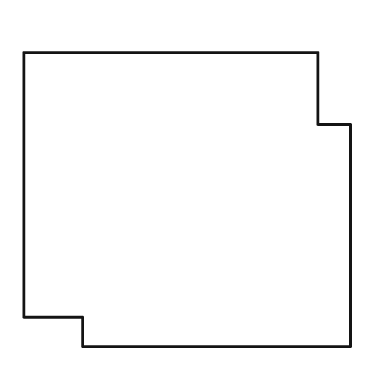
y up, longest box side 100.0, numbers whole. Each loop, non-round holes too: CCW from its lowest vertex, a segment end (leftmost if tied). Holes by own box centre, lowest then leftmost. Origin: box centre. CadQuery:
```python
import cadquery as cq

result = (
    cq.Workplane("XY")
    .moveTo(-32.0, -45.0)
    .lineTo(50.0, -45.0)
    .lineTo(50.0, 23.0)
    .lineTo(40.0, 23.0)
    .lineTo(40.0, 45.0)
    .lineTo(-50.0, 45.0)
    .lineTo(-50.0, -36.0)
    .lineTo(-32.0, -36.0)
    .close()
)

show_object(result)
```